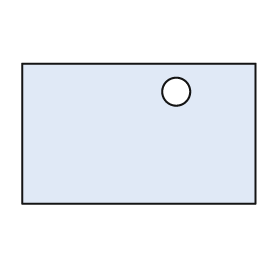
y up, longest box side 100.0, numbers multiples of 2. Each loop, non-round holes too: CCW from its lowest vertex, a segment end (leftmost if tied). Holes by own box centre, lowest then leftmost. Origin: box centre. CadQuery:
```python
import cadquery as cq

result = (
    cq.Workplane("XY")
    .moveTo(-50.0, -30.0)
    .lineTo(50.0, -30.0)
    .lineTo(50.0, 30.0)
    .lineTo(-50.0, 30.0)
    .close()
    .moveTo(16.0, 18.0)
    .circle(6.0)
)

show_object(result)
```